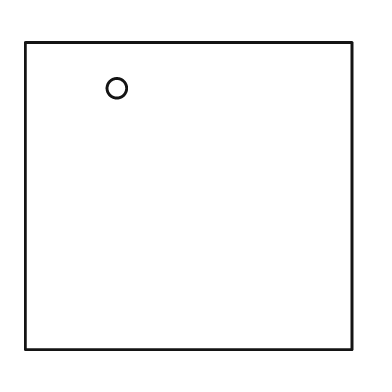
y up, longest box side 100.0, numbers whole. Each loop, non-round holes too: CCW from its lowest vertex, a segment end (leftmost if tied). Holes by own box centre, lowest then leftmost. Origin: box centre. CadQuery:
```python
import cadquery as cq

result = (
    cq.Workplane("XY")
    .moveTo(-50.0, -47.0)
    .lineTo(50.0, -47.0)
    .lineTo(50.0, 47.0)
    .lineTo(-50.0, 47.0)
    .close()
    .moveTo(-22.0, 33.0)
    .circle(3.0)
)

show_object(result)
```